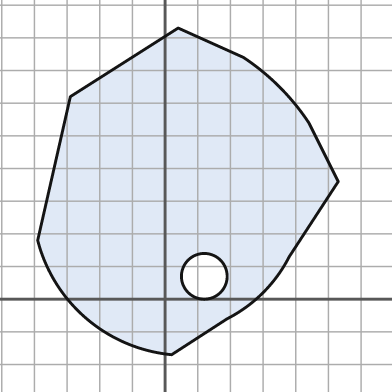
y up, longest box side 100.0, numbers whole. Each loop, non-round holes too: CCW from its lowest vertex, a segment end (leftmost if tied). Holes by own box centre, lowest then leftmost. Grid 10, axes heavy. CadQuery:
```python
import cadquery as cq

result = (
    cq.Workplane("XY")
    .moveTo(2.0, -17.0)
    .lineTo(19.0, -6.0)
    .threePointArc((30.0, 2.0), (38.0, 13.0))
    .lineTo(53.0, 36.0)
    .lineTo(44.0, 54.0)
    .threePointArc((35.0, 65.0), (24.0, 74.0))
    .lineTo(4.0, 83.0)
    .lineTo(-29.0, 62.0)
    .lineTo(-39.0, 18.0)
    .threePointArc((-24.0, -6.0), (2.0, -17.0))
    .close()
    .moveTo(12.0, 7.0)
    .circle(7.0)
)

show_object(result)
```